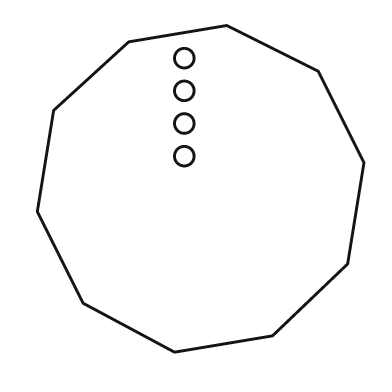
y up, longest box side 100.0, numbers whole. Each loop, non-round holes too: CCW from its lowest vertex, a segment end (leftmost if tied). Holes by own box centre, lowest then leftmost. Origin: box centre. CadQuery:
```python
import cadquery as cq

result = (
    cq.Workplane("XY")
    .moveTo(-8.0, -50.0)
    .lineTo(22.0, -45.0)
    .lineTo(45.0, -23.0)
    .lineTo(50.0, 8.0)
    .lineTo(36.0, 36.0)
    .lineTo(8.0, 50.0)
    .lineTo(-22.0, 45.0)
    .lineTo(-45.0, 24.0)
    .lineTo(-50.0, -7.0)
    .lineTo(-36.0, -35.0)
    .close()
    .moveTo(-5.0, 10.0)
    .circle(3.0)
    .moveTo(-5.0, 20.0)
    .circle(3.0)
    .moveTo(-5.0, 30.0)
    .circle(3.0)
    .moveTo(-5.0, 40.0)
    .circle(3.0)
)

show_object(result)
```